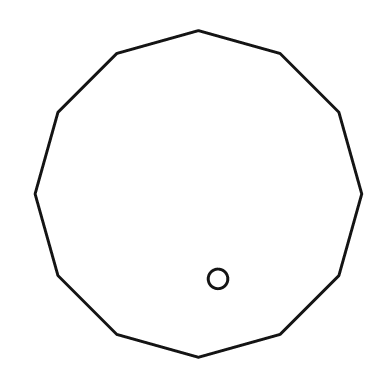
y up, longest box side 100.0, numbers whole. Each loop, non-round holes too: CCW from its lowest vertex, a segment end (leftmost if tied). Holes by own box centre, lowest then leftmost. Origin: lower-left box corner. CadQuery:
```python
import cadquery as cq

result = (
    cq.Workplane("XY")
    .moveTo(50.0, 0.0)
    .lineTo(75.0, 7.0)
    .lineTo(93.0, 25.0)
    .lineTo(100.0, 50.0)
    .lineTo(93.0, 75.0)
    .lineTo(75.0, 93.0)
    .lineTo(50.0, 100.0)
    .lineTo(25.0, 93.0)
    .lineTo(7.0, 75.0)
    .lineTo(0.0, 50.0)
    .lineTo(7.0, 25.0)
    .lineTo(25.0, 7.0)
    .close()
    .moveTo(56.0, 24.0)
    .circle(3.0)
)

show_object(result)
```